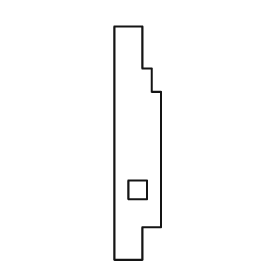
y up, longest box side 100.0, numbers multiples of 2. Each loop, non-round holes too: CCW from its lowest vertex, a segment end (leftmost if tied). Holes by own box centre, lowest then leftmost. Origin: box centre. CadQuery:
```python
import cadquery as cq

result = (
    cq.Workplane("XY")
    .moveTo(-10.0, -50.0)
    .lineTo(2.0, -50.0)
    .lineTo(2.0, -36.0)
    .lineTo(10.0, -36.0)
    .lineTo(10.0, 22.0)
    .lineTo(6.0, 22.0)
    .lineTo(6.0, 32.0)
    .lineTo(2.0, 32.0)
    .lineTo(2.0, 50.0)
    .lineTo(-10.0, 50.0)
    .close()
    .moveTo(-4.0, -24.0)
    .lineTo(4.0, -24.0)
    .lineTo(4.0, -16.0)
    .lineTo(-4.0, -16.0)
    .close()
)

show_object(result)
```